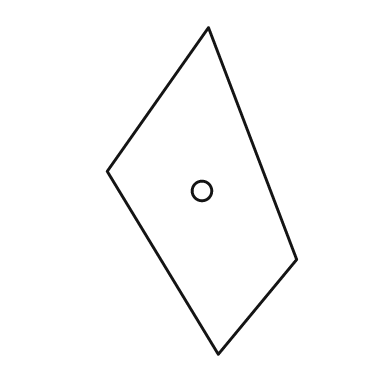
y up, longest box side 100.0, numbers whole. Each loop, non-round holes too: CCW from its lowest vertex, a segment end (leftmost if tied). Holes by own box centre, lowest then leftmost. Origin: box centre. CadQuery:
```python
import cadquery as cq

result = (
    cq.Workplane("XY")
    .moveTo(5.0, -50.0)
    .lineTo(29.0, -21.0)
    .lineTo(2.0, 50.0)
    .lineTo(-29.0, 6.0)
    .close()
    .moveTo(0.0, 0.0)
    .circle(3.0)
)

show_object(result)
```